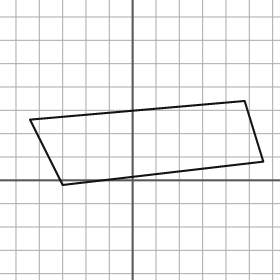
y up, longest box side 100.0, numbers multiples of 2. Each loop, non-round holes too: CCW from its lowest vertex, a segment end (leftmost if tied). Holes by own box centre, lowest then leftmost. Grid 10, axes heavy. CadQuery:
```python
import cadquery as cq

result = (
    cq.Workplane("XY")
    .moveTo(-30.0, -2.0)
    .lineTo(56.0, 8.0)
    .lineTo(48.0, 34.0)
    .lineTo(-44.0, 26.0)
    .close()
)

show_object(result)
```